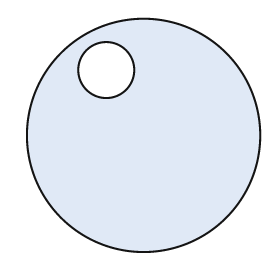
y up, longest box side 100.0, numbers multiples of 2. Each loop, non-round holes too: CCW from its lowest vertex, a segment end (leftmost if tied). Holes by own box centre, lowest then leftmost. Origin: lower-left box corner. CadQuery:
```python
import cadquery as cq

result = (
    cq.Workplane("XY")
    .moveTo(50.0, 50.0)
    .circle(50.0)
    .moveTo(34.0, 78.0)
    .circle(12.0)
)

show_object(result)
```